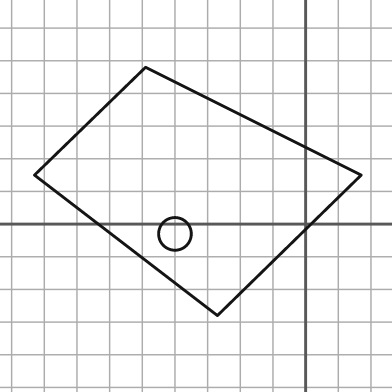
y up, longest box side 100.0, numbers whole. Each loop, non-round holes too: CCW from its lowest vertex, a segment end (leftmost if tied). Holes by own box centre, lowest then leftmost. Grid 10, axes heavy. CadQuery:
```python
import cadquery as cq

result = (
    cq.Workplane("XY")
    .moveTo(-27.0, -28.0)
    .lineTo(17.0, 15.0)
    .lineTo(-49.0, 48.0)
    .lineTo(-83.0, 15.0)
    .close()
    .moveTo(-40.0, -3.0)
    .circle(5.0)
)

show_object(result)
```